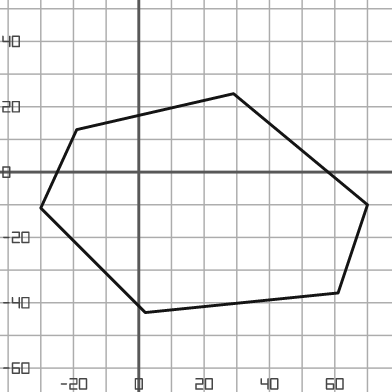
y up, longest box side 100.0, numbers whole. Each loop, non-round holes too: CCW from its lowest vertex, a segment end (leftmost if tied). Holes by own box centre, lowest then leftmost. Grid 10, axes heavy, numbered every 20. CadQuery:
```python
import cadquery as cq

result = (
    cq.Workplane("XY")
    .moveTo(2.0, -43.0)
    .lineTo(61.0, -37.0)
    .lineTo(70.0, -10.0)
    .lineTo(29.0, 24.0)
    .lineTo(-19.0, 13.0)
    .lineTo(-30.0, -11.0)
    .close()
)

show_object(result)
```